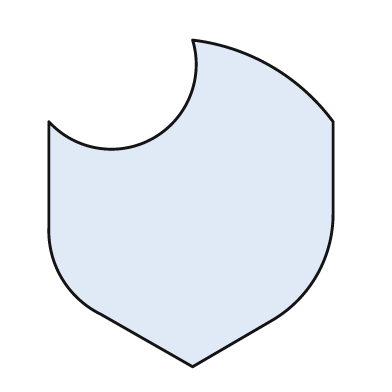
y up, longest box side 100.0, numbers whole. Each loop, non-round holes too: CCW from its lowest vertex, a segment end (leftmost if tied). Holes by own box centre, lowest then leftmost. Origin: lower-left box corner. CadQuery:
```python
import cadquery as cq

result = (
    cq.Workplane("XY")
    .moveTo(44.0, 0.0)
    .lineTo(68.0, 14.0)
    .threePointArc((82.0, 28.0), (87.0, 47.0))
    .lineTo(87.0, 75.0)
    .threePointArc((68.0, 92.0), (44.0, 100.0))
    .threePointArc((32.0, 70.0), (0.0, 75.0))
    .lineTo(0.0, 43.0)
    .threePointArc((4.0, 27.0), (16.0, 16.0))
    .close()
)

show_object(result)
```